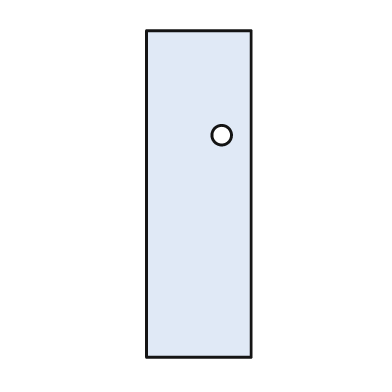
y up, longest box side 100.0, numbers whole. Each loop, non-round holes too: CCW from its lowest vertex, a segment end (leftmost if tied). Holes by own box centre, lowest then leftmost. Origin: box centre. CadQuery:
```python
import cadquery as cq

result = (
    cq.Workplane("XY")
    .moveTo(-16.0, -50.0)
    .lineTo(16.0, -50.0)
    .lineTo(16.0, 50.0)
    .lineTo(-16.0, 50.0)
    .close()
    .moveTo(7.0, 18.0)
    .circle(3.0)
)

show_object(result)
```